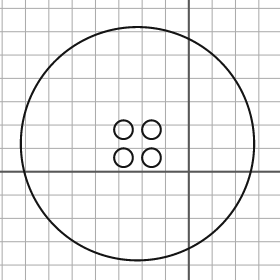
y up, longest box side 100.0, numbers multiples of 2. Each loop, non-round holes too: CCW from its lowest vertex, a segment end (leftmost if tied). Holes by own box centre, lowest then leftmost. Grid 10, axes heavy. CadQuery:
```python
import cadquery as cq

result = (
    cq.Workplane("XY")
    .moveTo(-22.0, 12.0)
    .circle(50.0)
    .moveTo(-28.0, 6.0)
    .circle(4.0)
    .moveTo(-16.0, 6.0)
    .circle(4.0)
    .moveTo(-28.0, 18.0)
    .circle(4.0)
    .moveTo(-16.0, 18.0)
    .circle(4.0)
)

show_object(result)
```